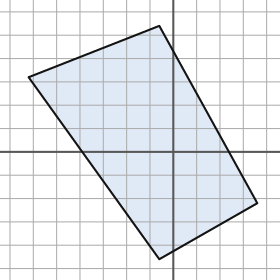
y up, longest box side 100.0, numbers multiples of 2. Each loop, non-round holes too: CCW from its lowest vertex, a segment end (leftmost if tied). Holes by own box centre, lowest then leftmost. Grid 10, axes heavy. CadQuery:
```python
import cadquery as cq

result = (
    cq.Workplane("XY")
    .moveTo(-6.0, -46.0)
    .lineTo(36.0, -22.0)
    .lineTo(-6.0, 54.0)
    .lineTo(-62.0, 32.0)
    .close()
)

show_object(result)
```